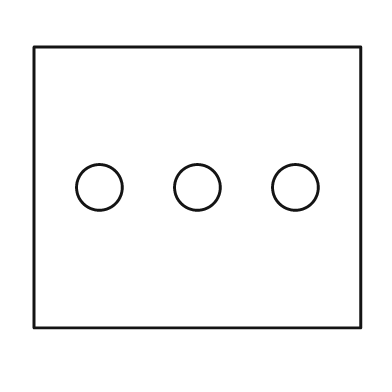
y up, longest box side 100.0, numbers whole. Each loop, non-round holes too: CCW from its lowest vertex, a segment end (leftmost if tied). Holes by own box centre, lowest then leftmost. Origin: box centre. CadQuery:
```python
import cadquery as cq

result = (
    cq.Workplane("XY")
    .moveTo(-50.0, -43.0)
    .lineTo(50.0, -43.0)
    .lineTo(50.0, 43.0)
    .lineTo(-50.0, 43.0)
    .close()
    .moveTo(-30.0, 0.0)
    .circle(7.0)
    .moveTo(0.0, 0.0)
    .circle(7.0)
    .moveTo(30.0, 0.0)
    .circle(7.0)
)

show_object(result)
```